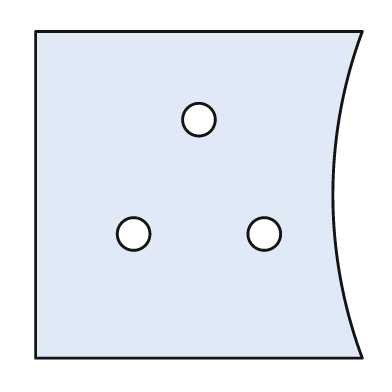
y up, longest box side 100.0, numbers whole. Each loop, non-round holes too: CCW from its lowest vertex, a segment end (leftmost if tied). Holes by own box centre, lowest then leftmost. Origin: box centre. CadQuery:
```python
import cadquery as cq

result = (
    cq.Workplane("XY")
    .moveTo(-50.0, -50.0)
    .lineTo(50.0, -50.0)
    .threePointArc((41.0, 0.0), (50.0, 50.0))
    .lineTo(-50.0, 50.0)
    .close()
    .moveTo(-20.0, -12.0)
    .circle(5.0)
    .moveTo(20.0, -12.0)
    .circle(5.0)
    .moveTo(0.0, 23.0)
    .circle(5.0)
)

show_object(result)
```